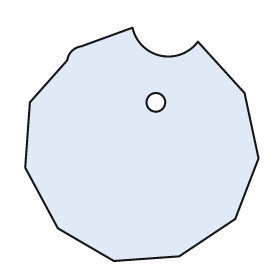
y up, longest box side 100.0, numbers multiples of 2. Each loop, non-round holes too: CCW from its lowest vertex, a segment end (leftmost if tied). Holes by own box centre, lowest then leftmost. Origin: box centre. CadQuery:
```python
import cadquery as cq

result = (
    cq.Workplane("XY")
    .moveTo(-12.0, -50.0)
    .lineTo(16.0, -48.0)
    .lineTo(40.0, -32.0)
    .lineTo(50.0, -6.0)
    .lineTo(44.0, 22.0)
    .lineTo(24.0, 44.0)
    .threePointArc((8.0, 38.0), (-4.0, 50.0))
    .lineTo(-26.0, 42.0)
    .threePointArc((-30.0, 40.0), (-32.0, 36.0))
    .lineTo(-48.0, 18.0)
    .lineTo(-50.0, -10.0)
    .lineTo(-36.0, -36.0)
    .close()
    .moveTo(6.0, 18.0)
    .circle(4.0)
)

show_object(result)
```